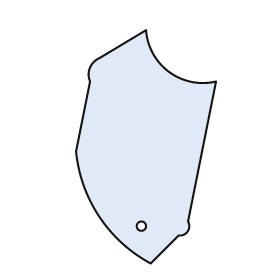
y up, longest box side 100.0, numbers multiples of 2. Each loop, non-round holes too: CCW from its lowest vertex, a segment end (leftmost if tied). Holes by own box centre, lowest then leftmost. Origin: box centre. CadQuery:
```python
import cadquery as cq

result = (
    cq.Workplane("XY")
    .moveTo(2.0, -50.0)
    .lineTo(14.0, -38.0)
    .threePointArc((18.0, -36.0), (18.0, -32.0))
    .lineTo(30.0, 28.0)
    .threePointArc((10.0, 32.0), (0.0, 50.0))
    .lineTo(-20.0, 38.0)
    .threePointArc((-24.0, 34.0), (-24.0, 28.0))
    .lineTo(-30.0, -2.0)
    .threePointArc((-20.0, -30.0), (2.0, -50.0))
    .close()
    .moveTo(-2.0, -34.0)
    .circle(2.0)
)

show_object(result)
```